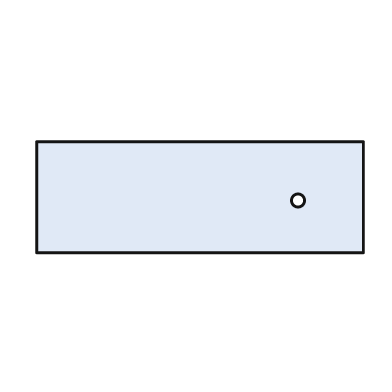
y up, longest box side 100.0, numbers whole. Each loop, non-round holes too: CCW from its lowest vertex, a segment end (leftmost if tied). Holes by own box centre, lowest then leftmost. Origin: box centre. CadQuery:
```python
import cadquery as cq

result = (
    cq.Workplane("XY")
    .moveTo(-50.0, -17.0)
    .lineTo(50.0, -17.0)
    .lineTo(50.0, 17.0)
    .lineTo(-50.0, 17.0)
    .close()
    .moveTo(30.0, -1.0)
    .circle(2.0)
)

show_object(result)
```